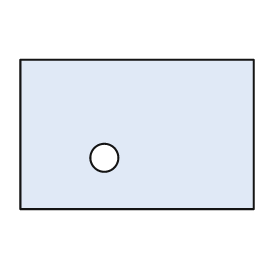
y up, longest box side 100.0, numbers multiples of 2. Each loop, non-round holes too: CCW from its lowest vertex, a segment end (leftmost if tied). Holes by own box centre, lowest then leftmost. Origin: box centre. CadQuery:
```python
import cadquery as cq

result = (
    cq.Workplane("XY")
    .moveTo(-50.0, -32.0)
    .lineTo(50.0, -32.0)
    .lineTo(50.0, 32.0)
    .lineTo(-50.0, 32.0)
    .close()
    .moveTo(-14.0, -10.0)
    .circle(6.0)
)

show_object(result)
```